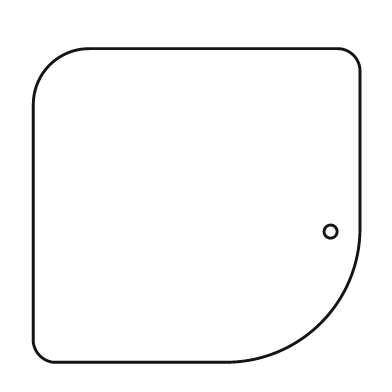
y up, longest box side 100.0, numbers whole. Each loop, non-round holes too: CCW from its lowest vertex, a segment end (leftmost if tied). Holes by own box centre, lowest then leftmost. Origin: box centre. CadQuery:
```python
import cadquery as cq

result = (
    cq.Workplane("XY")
    .moveTo(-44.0, -48.0)
    .lineTo(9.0, -48.0)
    .threePointArc((38.0, -36.0), (50.0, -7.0))
    .lineTo(50.0, 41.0)
    .threePointArc((48.0, 46.0), (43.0, 48.0))
    .lineTo(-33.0, 48.0)
    .threePointArc((-45.0, 43.0), (-50.0, 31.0))
    .lineTo(-50.0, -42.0)
    .threePointArc((-48.0, -46.0), (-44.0, -48.0))
    .close()
    .moveTo(41.0, -8.0)
    .circle(2.0)
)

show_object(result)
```